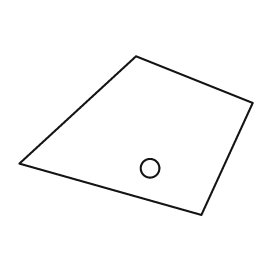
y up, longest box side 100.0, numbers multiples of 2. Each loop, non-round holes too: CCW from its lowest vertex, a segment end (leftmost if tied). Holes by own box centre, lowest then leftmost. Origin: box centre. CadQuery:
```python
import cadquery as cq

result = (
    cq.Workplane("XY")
    .moveTo(28.0, -34.0)
    .lineTo(50.0, 14.0)
    .lineTo(0.0, 34.0)
    .lineTo(-50.0, -12.0)
    .close()
    .moveTo(6.0, -14.0)
    .circle(4.0)
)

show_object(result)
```